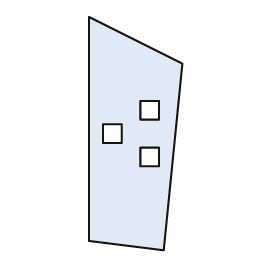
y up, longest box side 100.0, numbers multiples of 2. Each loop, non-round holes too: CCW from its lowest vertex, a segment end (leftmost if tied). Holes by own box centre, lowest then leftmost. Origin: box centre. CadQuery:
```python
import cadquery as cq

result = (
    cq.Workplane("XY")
    .moveTo(12.0, -50.0)
    .lineTo(20.0, 30.0)
    .lineTo(-20.0, 50.0)
    .lineTo(-20.0, -46.0)
    .close()
    .moveTo(2.0, -14.0)
    .lineTo(10.0, -14.0)
    .lineTo(10.0, -6.0)
    .lineTo(2.0, -6.0)
    .close()
    .moveTo(-14.0, -4.0)
    .lineTo(-6.0, -4.0)
    .lineTo(-6.0, 4.0)
    .lineTo(-14.0, 4.0)
    .close()
    .moveTo(2.0, 6.0)
    .lineTo(10.0, 6.0)
    .lineTo(10.0, 14.0)
    .lineTo(2.0, 14.0)
    .close()
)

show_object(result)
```